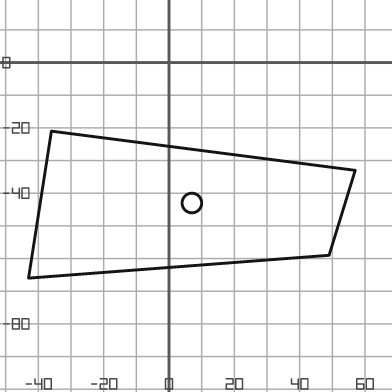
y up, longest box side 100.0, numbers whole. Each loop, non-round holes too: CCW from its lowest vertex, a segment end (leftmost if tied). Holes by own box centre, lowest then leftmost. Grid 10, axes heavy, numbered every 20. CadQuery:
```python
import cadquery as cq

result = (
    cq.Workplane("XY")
    .moveTo(-43.0, -66.0)
    .lineTo(49.0, -59.0)
    .lineTo(57.0, -33.0)
    .lineTo(-36.0, -21.0)
    .close()
    .moveTo(7.0, -43.0)
    .circle(3.0)
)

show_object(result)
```